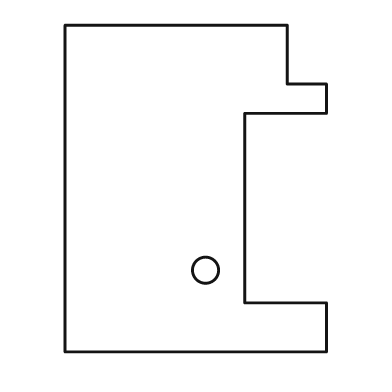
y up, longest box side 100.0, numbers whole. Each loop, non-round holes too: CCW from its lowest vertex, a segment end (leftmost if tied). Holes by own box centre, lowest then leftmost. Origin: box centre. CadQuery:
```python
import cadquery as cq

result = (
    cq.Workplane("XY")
    .moveTo(-40.0, -50.0)
    .lineTo(40.0, -50.0)
    .lineTo(40.0, -35.0)
    .lineTo(15.0, -35.0)
    .lineTo(15.0, 23.0)
    .lineTo(40.0, 23.0)
    .lineTo(40.0, 32.0)
    .lineTo(28.0, 32.0)
    .lineTo(28.0, 50.0)
    .lineTo(-40.0, 50.0)
    .close()
    .moveTo(3.0, -25.0)
    .circle(4.0)
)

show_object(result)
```